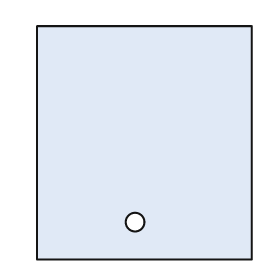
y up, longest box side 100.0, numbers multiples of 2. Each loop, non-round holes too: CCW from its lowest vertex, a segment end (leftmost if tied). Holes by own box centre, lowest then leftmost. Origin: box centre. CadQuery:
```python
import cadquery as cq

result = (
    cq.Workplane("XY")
    .moveTo(-46.0, -50.0)
    .lineTo(46.0, -50.0)
    .lineTo(46.0, 50.0)
    .lineTo(-46.0, 50.0)
    .close()
    .moveTo(-4.0, -34.0)
    .circle(4.0)
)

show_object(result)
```